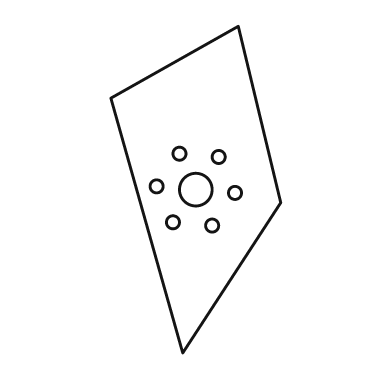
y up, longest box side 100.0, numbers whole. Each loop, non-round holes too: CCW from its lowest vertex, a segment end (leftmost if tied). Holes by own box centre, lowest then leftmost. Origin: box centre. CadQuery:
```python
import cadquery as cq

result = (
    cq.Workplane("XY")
    .moveTo(-4.0, -50.0)
    .lineTo(26.0, -4.0)
    .lineTo(13.0, 50.0)
    .lineTo(-26.0, 28.0)
    .close()
    .moveTo(5.0, -11.0)
    .circle(2.0)
    .moveTo(-7.0, -10.0)
    .circle(2.0)
    .moveTo(12.0, -1.0)
    .circle(2.0)
    .moveTo(0.0, 0.0)
    .circle(5.0)
    .moveTo(-12.0, 1.0)
    .circle(2.0)
    .moveTo(7.0, 10.0)
    .circle(2.0)
    .moveTo(-5.0, 11.0)
    .circle(2.0)
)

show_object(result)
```